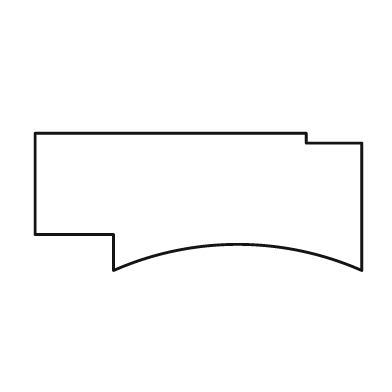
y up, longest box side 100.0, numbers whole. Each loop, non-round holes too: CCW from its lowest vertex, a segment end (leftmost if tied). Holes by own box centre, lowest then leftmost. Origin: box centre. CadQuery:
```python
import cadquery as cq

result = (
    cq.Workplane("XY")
    .moveTo(-26.0, -21.0)
    .threePointArc((12.0, -13.0), (50.0, -21.0))
    .lineTo(50.0, 18.0)
    .lineTo(33.0, 18.0)
    .lineTo(33.0, 21.0)
    .lineTo(-50.0, 21.0)
    .lineTo(-50.0, -10.0)
    .lineTo(-26.0, -10.0)
    .close()
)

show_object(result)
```